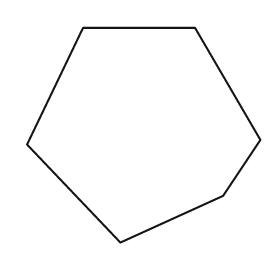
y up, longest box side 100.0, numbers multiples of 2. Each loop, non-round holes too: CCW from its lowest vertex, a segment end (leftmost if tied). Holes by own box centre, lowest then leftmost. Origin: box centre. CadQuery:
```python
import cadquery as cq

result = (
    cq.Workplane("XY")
    .moveTo(-10.0, -46.0)
    .lineTo(34.0, -26.0)
    .lineTo(50.0, -2.0)
    .lineTo(22.0, 46.0)
    .lineTo(-26.0, 46.0)
    .lineTo(-50.0, -4.0)
    .close()
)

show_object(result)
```